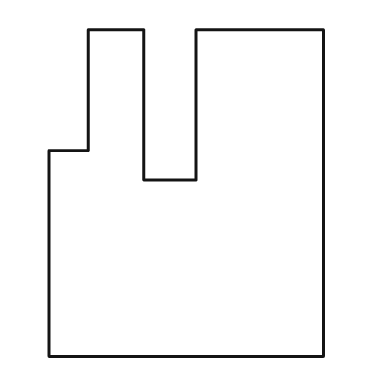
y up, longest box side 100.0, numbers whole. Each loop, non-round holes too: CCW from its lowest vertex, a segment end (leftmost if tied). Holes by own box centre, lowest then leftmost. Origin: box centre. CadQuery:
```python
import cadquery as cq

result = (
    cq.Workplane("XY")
    .moveTo(-42.0, -50.0)
    .lineTo(42.0, -50.0)
    .lineTo(42.0, 50.0)
    .lineTo(3.0, 50.0)
    .lineTo(3.0, 4.0)
    .lineTo(-13.0, 4.0)
    .lineTo(-13.0, 50.0)
    .lineTo(-30.0, 50.0)
    .lineTo(-30.0, 13.0)
    .lineTo(-42.0, 13.0)
    .close()
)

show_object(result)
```